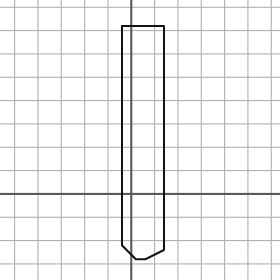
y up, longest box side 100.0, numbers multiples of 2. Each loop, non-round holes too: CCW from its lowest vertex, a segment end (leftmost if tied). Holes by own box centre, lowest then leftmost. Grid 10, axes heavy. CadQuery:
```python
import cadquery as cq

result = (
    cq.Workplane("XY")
    .moveTo(2.0, -28.0)
    .lineTo(6.0, -28.0)
    .lineTo(14.0, -24.0)
    .lineTo(14.0, 72.0)
    .lineTo(-4.0, 72.0)
    .lineTo(-4.0, -22.0)
    .close()
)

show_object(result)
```